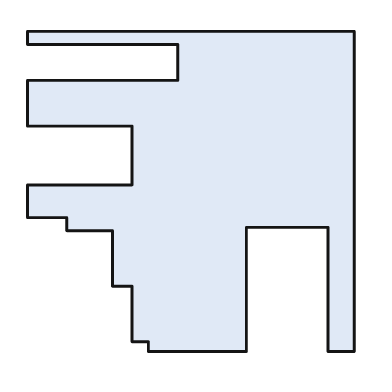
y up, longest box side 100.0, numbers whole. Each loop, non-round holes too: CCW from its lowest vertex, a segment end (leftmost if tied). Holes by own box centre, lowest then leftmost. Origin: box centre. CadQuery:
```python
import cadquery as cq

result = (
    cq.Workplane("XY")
    .moveTo(-13.0, -49.0)
    .lineTo(17.0, -49.0)
    .lineTo(17.0, -11.0)
    .lineTo(42.0, -11.0)
    .lineTo(42.0, -49.0)
    .lineTo(50.0, -49.0)
    .lineTo(50.0, 49.0)
    .lineTo(-50.0, 49.0)
    .lineTo(-50.0, 45.0)
    .lineTo(-4.0, 45.0)
    .lineTo(-4.0, 34.0)
    .lineTo(-50.0, 34.0)
    .lineTo(-50.0, 20.0)
    .lineTo(-18.0, 20.0)
    .lineTo(-18.0, 2.0)
    .lineTo(-50.0, 2.0)
    .lineTo(-50.0, -8.0)
    .lineTo(-38.0, -8.0)
    .lineTo(-38.0, -12.0)
    .lineTo(-24.0, -12.0)
    .lineTo(-24.0, -29.0)
    .lineTo(-18.0, -29.0)
    .lineTo(-18.0, -46.0)
    .lineTo(-13.0, -46.0)
    .close()
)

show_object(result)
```